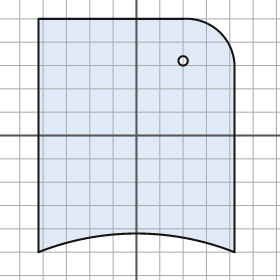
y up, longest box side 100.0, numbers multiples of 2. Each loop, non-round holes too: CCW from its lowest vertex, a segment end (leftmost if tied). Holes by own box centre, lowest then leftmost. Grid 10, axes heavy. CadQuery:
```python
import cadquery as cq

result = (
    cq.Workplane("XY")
    .moveTo(-42.0, -50.0)
    .threePointArc((0.0, -42.0), (42.0, -50.0))
    .lineTo(42.0, 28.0)
    .threePointArc((36.0, 44.0), (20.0, 50.0))
    .lineTo(-42.0, 50.0)
    .close()
    .moveTo(20.0, 32.0)
    .circle(2.0)
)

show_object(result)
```